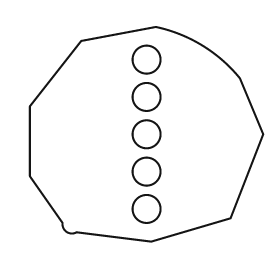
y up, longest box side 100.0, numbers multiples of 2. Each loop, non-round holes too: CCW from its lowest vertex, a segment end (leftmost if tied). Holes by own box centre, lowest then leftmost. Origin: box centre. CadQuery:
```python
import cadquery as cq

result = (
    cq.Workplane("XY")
    .moveTo(2.0, -46.0)
    .lineTo(36.0, -36.0)
    .lineTo(50.0, 0.0)
    .lineTo(40.0, 24.0)
    .threePointArc((24.0, 38.0), (4.0, 46.0))
    .lineTo(-28.0, 40.0)
    .lineTo(-50.0, 12.0)
    .lineTo(-50.0, -18.0)
    .lineTo(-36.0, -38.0)
    .threePointArc((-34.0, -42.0), (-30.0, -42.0))
    .close()
    .moveTo(0.0, -32.0)
    .circle(6.0)
    .moveTo(0.0, -16.0)
    .circle(6.0)
    .moveTo(0.0, 0.0)
    .circle(6.0)
    .moveTo(0.0, 16.0)
    .circle(6.0)
    .moveTo(0.0, 32.0)
    .circle(6.0)
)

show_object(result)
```